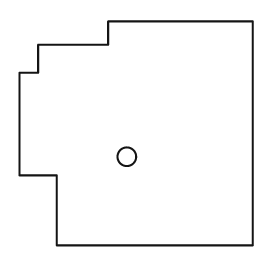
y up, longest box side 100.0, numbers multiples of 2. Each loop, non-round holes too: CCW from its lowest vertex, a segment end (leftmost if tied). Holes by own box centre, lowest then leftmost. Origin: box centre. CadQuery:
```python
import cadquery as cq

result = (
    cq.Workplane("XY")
    .moveTo(-34.0, -48.0)
    .lineTo(50.0, -48.0)
    .lineTo(50.0, 48.0)
    .lineTo(-12.0, 48.0)
    .lineTo(-12.0, 38.0)
    .lineTo(-42.0, 38.0)
    .lineTo(-42.0, 26.0)
    .lineTo(-50.0, 26.0)
    .lineTo(-50.0, -18.0)
    .lineTo(-34.0, -18.0)
    .close()
    .moveTo(-4.0, -10.0)
    .circle(4.0)
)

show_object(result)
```